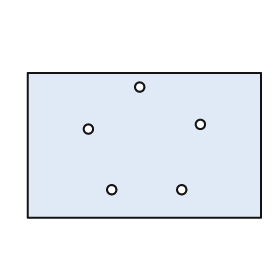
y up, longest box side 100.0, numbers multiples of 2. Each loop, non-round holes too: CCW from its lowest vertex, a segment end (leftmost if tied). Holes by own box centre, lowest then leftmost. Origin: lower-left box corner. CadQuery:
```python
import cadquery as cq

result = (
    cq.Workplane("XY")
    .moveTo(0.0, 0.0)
    .lineTo(100.0, 0.0)
    .lineTo(100.0, 62.0)
    .lineTo(0.0, 62.0)
    .close()
    .moveTo(36.0, 12.0)
    .circle(2.0)
    .moveTo(66.0, 12.0)
    .circle(2.0)
    .moveTo(26.0, 38.0)
    .circle(2.0)
    .moveTo(74.0, 40.0)
    .circle(2.0)
    .moveTo(48.0, 56.0)
    .circle(2.0)
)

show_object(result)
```